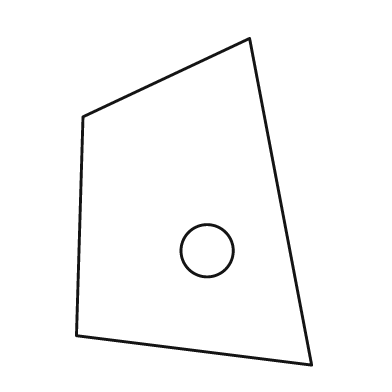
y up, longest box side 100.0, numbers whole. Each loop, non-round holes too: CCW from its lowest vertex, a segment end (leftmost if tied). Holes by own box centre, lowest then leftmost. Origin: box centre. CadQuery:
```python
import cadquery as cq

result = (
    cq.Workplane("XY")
    .moveTo(36.0, -50.0)
    .lineTo(17.0, 50.0)
    .lineTo(-34.0, 26.0)
    .lineTo(-36.0, -41.0)
    .close()
    .moveTo(4.0, -15.0)
    .circle(8.0)
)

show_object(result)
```